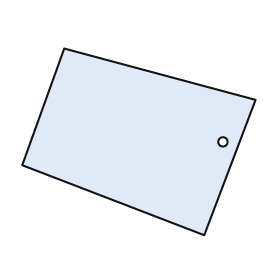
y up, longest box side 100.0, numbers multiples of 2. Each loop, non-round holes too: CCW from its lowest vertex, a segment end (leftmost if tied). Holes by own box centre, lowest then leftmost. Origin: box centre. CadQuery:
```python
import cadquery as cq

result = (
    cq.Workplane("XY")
    .moveTo(28.0, -40.0)
    .lineTo(50.0, 18.0)
    .lineTo(-32.0, 40.0)
    .lineTo(-50.0, -10.0)
    .close()
    .moveTo(36.0, 0.0)
    .circle(2.0)
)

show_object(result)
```